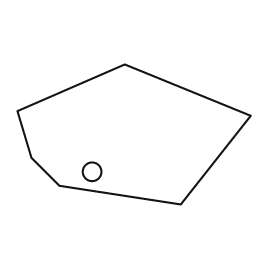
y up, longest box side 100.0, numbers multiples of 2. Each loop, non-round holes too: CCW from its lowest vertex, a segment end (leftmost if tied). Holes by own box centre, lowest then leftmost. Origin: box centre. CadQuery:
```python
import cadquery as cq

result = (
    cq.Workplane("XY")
    .moveTo(20.0, -30.0)
    .lineTo(50.0, 8.0)
    .lineTo(-4.0, 30.0)
    .lineTo(-50.0, 10.0)
    .lineTo(-44.0, -10.0)
    .lineTo(-32.0, -22.0)
    .close()
    .moveTo(-18.0, -16.0)
    .circle(4.0)
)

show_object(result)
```